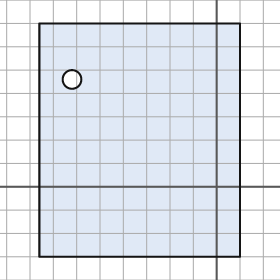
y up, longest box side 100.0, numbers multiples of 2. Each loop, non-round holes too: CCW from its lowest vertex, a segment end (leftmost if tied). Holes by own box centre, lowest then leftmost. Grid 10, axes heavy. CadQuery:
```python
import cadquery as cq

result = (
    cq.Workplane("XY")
    .moveTo(-76.0, -30.0)
    .lineTo(10.0, -30.0)
    .lineTo(10.0, 70.0)
    .lineTo(-76.0, 70.0)
    .close()
    .moveTo(-62.0, 46.0)
    .circle(4.0)
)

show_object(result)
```